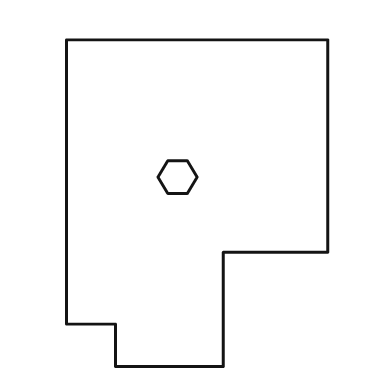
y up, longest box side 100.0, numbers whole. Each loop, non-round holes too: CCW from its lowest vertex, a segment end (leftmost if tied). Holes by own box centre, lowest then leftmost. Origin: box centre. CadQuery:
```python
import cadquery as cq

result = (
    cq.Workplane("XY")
    .moveTo(-25.0, -50.0)
    .lineTo(8.0, -50.0)
    .lineTo(8.0, -15.0)
    .lineTo(40.0, -15.0)
    .lineTo(40.0, 50.0)
    .lineTo(-40.0, 50.0)
    .lineTo(-40.0, -37.0)
    .lineTo(-25.0, -37.0)
    .close()
    .moveTo(-9.0, 3.0)
    .lineTo(-3.0, 3.0)
    .lineTo(0.0, 8.0)
    .lineTo(-3.0, 13.0)
    .lineTo(-9.0, 13.0)
    .lineTo(-12.0, 8.0)
    .close()
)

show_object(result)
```